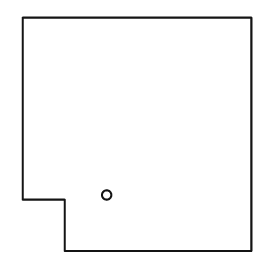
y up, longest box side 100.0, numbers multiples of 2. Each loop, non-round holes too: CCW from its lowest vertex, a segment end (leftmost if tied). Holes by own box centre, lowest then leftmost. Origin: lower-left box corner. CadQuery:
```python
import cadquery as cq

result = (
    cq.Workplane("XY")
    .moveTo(18.0, 0.0)
    .lineTo(98.0, 0.0)
    .lineTo(98.0, 100.0)
    .lineTo(0.0, 100.0)
    .lineTo(0.0, 22.0)
    .lineTo(18.0, 22.0)
    .close()
    .moveTo(36.0, 24.0)
    .circle(2.0)
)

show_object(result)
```